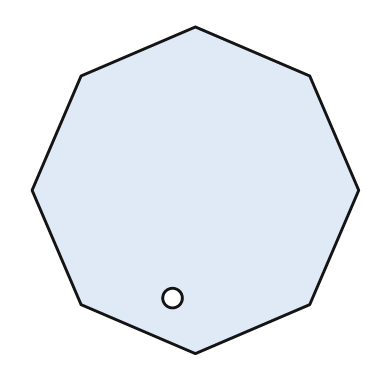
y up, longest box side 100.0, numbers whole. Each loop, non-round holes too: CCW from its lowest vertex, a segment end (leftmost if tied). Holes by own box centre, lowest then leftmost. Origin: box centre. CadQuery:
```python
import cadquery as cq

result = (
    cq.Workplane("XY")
    .moveTo(0.0, -50.0)
    .lineTo(35.0, -35.0)
    .lineTo(50.0, 0.0)
    .lineTo(35.0, 35.0)
    .lineTo(0.0, 50.0)
    .lineTo(-35.0, 35.0)
    .lineTo(-50.0, 0.0)
    .lineTo(-35.0, -35.0)
    .close()
    .moveTo(-7.0, -33.0)
    .circle(3.0)
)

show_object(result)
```